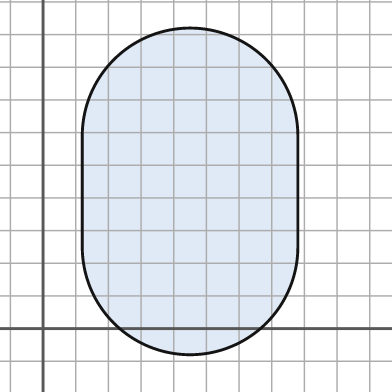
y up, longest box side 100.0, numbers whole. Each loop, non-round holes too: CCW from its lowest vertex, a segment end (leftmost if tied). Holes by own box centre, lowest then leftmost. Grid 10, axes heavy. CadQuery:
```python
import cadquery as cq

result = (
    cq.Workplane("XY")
    .moveTo(12.0, 25.0)
    .threePointArc((45.0, -8.0), (78.0, 25.0))
    .lineTo(78.0, 59.0)
    .threePointArc((45.0, 92.0), (12.0, 59.0))
    .close()
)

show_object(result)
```